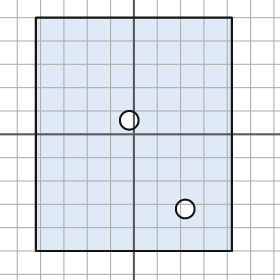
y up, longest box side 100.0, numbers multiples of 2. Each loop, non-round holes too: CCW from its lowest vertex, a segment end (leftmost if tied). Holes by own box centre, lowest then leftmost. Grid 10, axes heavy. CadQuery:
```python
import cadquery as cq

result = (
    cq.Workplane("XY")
    .moveTo(-42.0, -50.0)
    .lineTo(42.0, -50.0)
    .lineTo(42.0, 50.0)
    .lineTo(-42.0, 50.0)
    .close()
    .moveTo(22.0, -32.0)
    .circle(4.0)
    .moveTo(-2.0, 6.0)
    .circle(4.0)
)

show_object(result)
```